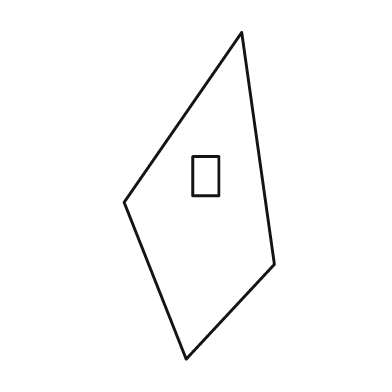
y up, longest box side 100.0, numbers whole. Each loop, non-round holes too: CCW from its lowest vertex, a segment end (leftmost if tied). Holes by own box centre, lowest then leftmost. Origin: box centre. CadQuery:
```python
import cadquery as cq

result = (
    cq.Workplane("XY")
    .moveTo(-4.0, -50.0)
    .lineTo(23.0, -21.0)
    .lineTo(13.0, 50.0)
    .lineTo(-23.0, -2.0)
    .close()
    .moveTo(-2.0, 0.0)
    .lineTo(6.0, 0.0)
    .lineTo(6.0, 12.0)
    .lineTo(-2.0, 12.0)
    .close()
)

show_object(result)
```